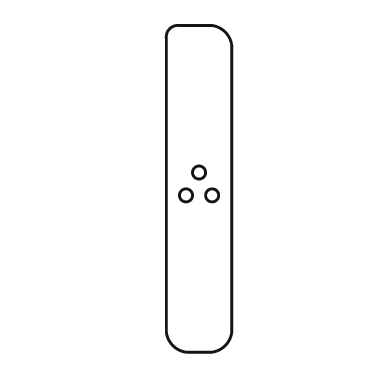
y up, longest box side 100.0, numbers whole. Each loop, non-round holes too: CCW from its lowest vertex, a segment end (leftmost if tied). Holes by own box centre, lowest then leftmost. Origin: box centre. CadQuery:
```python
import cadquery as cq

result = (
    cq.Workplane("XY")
    .moveTo(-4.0, -50.0)
    .lineTo(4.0, -50.0)
    .threePointArc((8.0, -48.0), (10.0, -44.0))
    .lineTo(10.0, 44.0)
    .threePointArc((8.0, 48.0), (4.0, 50.0))
    .lineTo(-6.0, 50.0)
    .threePointArc((-9.0, 49.0), (-10.0, 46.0))
    .lineTo(-10.0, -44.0)
    .threePointArc((-8.0, -48.0), (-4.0, -50.0))
    .close()
    .moveTo(-4.0, -2.0)
    .circle(2.0)
    .moveTo(4.0, -2.0)
    .circle(2.0)
    .moveTo(0.0, 5.0)
    .circle(2.0)
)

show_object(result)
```